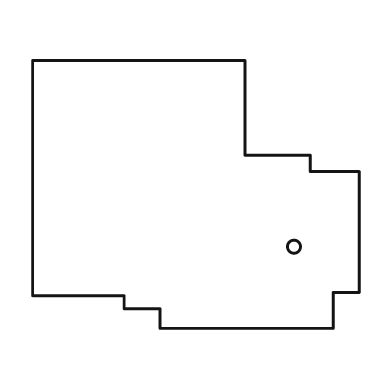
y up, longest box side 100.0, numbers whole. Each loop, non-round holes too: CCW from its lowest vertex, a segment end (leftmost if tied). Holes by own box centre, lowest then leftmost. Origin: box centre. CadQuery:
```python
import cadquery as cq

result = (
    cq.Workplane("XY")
    .moveTo(-11.0, -41.0)
    .lineTo(42.0, -41.0)
    .lineTo(42.0, -30.0)
    .lineTo(50.0, -30.0)
    .lineTo(50.0, 7.0)
    .lineTo(35.0, 7.0)
    .lineTo(35.0, 12.0)
    .lineTo(15.0, 12.0)
    .lineTo(15.0, 41.0)
    .lineTo(-50.0, 41.0)
    .lineTo(-50.0, -31.0)
    .lineTo(-22.0, -31.0)
    .lineTo(-22.0, -35.0)
    .lineTo(-11.0, -35.0)
    .close()
    .moveTo(30.0, -16.0)
    .circle(2.0)
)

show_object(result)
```